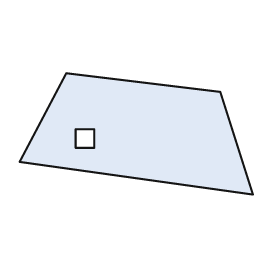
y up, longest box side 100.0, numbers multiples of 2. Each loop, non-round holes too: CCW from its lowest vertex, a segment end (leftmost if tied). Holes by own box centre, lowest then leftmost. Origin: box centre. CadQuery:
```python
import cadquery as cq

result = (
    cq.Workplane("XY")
    .moveTo(50.0, -26.0)
    .lineTo(36.0, 18.0)
    .lineTo(-30.0, 26.0)
    .lineTo(-50.0, -12.0)
    .close()
    .moveTo(-26.0, -6.0)
    .lineTo(-18.0, -6.0)
    .lineTo(-18.0, 2.0)
    .lineTo(-26.0, 2.0)
    .close()
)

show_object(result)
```